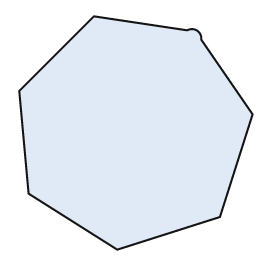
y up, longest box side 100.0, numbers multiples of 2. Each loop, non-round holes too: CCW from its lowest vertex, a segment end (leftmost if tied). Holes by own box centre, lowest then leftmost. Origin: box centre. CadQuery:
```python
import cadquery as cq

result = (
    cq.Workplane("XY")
    .moveTo(-8.0, -50.0)
    .lineTo(36.0, -36.0)
    .lineTo(50.0, 8.0)
    .lineTo(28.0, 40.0)
    .threePointArc((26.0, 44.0), (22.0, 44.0))
    .lineTo(-18.0, 50.0)
    .lineTo(-50.0, 18.0)
    .lineTo(-46.0, -26.0)
    .close()
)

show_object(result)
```